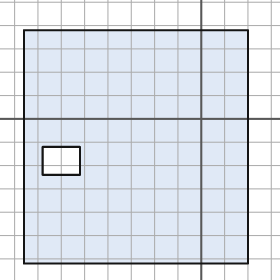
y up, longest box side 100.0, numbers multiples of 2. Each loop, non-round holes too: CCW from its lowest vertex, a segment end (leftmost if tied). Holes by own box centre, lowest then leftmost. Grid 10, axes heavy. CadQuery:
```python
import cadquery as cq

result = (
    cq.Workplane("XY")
    .moveTo(-76.0, -62.0)
    .lineTo(20.0, -62.0)
    .lineTo(20.0, 38.0)
    .lineTo(-76.0, 38.0)
    .close()
    .moveTo(-68.0, -24.0)
    .lineTo(-52.0, -24.0)
    .lineTo(-52.0, -12.0)
    .lineTo(-68.0, -12.0)
    .close()
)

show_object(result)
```